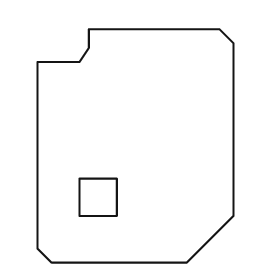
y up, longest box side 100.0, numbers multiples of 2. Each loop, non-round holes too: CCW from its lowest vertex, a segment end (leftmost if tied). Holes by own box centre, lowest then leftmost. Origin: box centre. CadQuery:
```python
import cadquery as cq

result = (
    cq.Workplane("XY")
    .moveTo(-36.0, -50.0)
    .lineTo(22.0, -50.0)
    .lineTo(42.0, -30.0)
    .lineTo(42.0, 44.0)
    .lineTo(36.0, 50.0)
    .lineTo(-20.0, 50.0)
    .lineTo(-20.0, 42.0)
    .lineTo(-24.0, 36.0)
    .lineTo(-42.0, 36.0)
    .lineTo(-42.0, -44.0)
    .close()
    .moveTo(-24.0, -30.0)
    .lineTo(-8.0, -30.0)
    .lineTo(-8.0, -14.0)
    .lineTo(-24.0, -14.0)
    .close()
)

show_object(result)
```